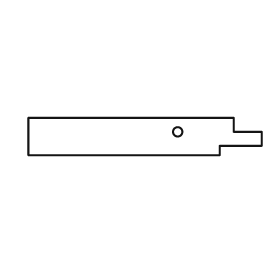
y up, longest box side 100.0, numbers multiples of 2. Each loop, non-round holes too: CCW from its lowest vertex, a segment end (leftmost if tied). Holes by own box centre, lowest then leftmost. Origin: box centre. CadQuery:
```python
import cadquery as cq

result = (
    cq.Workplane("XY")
    .moveTo(-50.0, -8.0)
    .lineTo(32.0, -8.0)
    .lineTo(32.0, -4.0)
    .lineTo(50.0, -4.0)
    .lineTo(50.0, 2.0)
    .lineTo(38.0, 2.0)
    .lineTo(38.0, 8.0)
    .lineTo(-50.0, 8.0)
    .close()
    .moveTo(14.0, 2.0)
    .circle(2.0)
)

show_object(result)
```